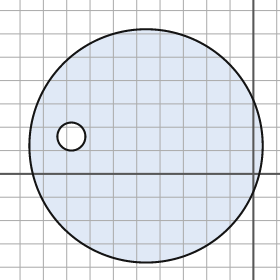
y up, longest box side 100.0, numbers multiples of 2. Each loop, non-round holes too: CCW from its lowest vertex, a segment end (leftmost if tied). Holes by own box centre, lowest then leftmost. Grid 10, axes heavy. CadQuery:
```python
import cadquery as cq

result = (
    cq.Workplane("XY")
    .moveTo(-46.0, 12.0)
    .circle(50.0)
    .moveTo(-78.0, 16.0)
    .circle(6.0)
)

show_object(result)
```